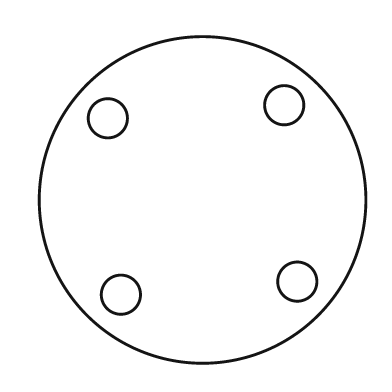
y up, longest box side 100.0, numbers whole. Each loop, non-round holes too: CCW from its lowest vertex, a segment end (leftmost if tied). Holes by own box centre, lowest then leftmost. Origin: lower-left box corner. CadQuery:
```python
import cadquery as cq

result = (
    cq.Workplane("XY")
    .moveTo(50.0, 50.0)
    .circle(50.0)
    .moveTo(25.0, 21.0)
    .circle(6.0)
    .moveTo(79.0, 25.0)
    .circle(6.0)
    .moveTo(21.0, 75.0)
    .circle(6.0)
    .moveTo(75.0, 79.0)
    .circle(6.0)
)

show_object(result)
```